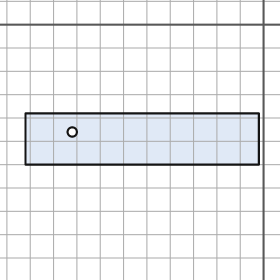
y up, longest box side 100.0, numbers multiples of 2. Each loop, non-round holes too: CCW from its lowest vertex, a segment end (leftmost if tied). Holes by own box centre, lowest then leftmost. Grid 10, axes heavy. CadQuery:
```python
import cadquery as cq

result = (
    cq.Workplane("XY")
    .moveTo(-102.0, -60.0)
    .lineTo(-2.0, -60.0)
    .lineTo(-2.0, -38.0)
    .lineTo(-102.0, -38.0)
    .close()
    .moveTo(-82.0, -46.0)
    .circle(2.0)
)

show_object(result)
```